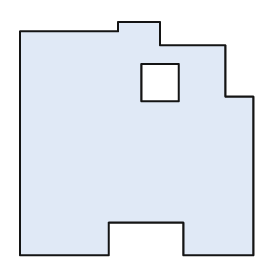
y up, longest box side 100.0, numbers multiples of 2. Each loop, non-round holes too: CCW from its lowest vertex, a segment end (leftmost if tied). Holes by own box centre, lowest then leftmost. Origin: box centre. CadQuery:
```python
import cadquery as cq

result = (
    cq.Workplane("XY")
    .moveTo(-50.0, -50.0)
    .lineTo(-12.0, -50.0)
    .lineTo(-12.0, -36.0)
    .lineTo(20.0, -36.0)
    .lineTo(20.0, -50.0)
    .lineTo(50.0, -50.0)
    .lineTo(50.0, 18.0)
    .lineTo(38.0, 18.0)
    .lineTo(38.0, 40.0)
    .lineTo(10.0, 40.0)
    .lineTo(10.0, 50.0)
    .lineTo(-8.0, 50.0)
    .lineTo(-8.0, 46.0)
    .lineTo(-50.0, 46.0)
    .close()
    .moveTo(2.0, 16.0)
    .lineTo(18.0, 16.0)
    .lineTo(18.0, 32.0)
    .lineTo(2.0, 32.0)
    .close()
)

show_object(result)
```